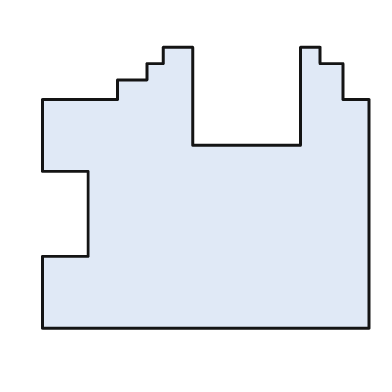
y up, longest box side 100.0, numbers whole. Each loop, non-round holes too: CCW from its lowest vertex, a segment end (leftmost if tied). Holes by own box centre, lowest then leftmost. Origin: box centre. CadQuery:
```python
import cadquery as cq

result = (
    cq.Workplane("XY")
    .moveTo(-50.0, -43.0)
    .lineTo(50.0, -43.0)
    .lineTo(50.0, 27.0)
    .lineTo(42.0, 27.0)
    .lineTo(42.0, 38.0)
    .lineTo(35.0, 38.0)
    .lineTo(35.0, 43.0)
    .lineTo(29.0, 43.0)
    .lineTo(29.0, 13.0)
    .lineTo(-4.0, 13.0)
    .lineTo(-4.0, 43.0)
    .lineTo(-13.0, 43.0)
    .lineTo(-13.0, 38.0)
    .lineTo(-18.0, 38.0)
    .lineTo(-18.0, 33.0)
    .lineTo(-27.0, 33.0)
    .lineTo(-27.0, 27.0)
    .lineTo(-50.0, 27.0)
    .lineTo(-50.0, 5.0)
    .lineTo(-36.0, 5.0)
    .lineTo(-36.0, -21.0)
    .lineTo(-50.0, -21.0)
    .close()
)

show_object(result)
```